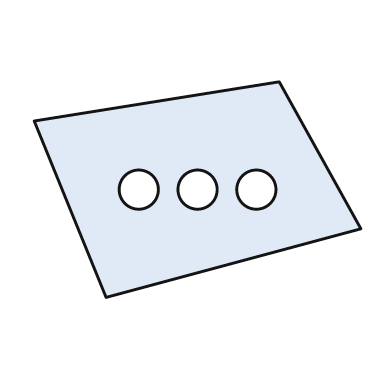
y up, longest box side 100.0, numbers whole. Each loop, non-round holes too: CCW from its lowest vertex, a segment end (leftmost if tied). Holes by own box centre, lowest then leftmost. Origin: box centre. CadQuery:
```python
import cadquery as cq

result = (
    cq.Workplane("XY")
    .moveTo(-28.0, -33.0)
    .lineTo(50.0, -12.0)
    .lineTo(25.0, 33.0)
    .lineTo(-50.0, 21.0)
    .close()
    .moveTo(-18.0, 0.0)
    .circle(6.0)
    .moveTo(0.0, 0.0)
    .circle(6.0)
    .moveTo(18.0, 0.0)
    .circle(6.0)
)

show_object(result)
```